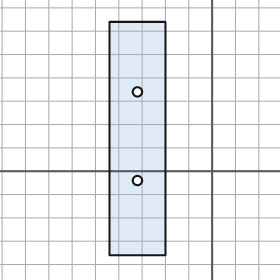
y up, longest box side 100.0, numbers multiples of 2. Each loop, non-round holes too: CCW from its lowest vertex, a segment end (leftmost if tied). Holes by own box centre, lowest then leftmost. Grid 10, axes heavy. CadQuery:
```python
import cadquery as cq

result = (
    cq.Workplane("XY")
    .moveTo(-44.0, -36.0)
    .lineTo(-20.0, -36.0)
    .lineTo(-20.0, 64.0)
    .lineTo(-44.0, 64.0)
    .close()
    .moveTo(-32.0, -4.0)
    .circle(2.0)
    .moveTo(-32.0, 34.0)
    .circle(2.0)
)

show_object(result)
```